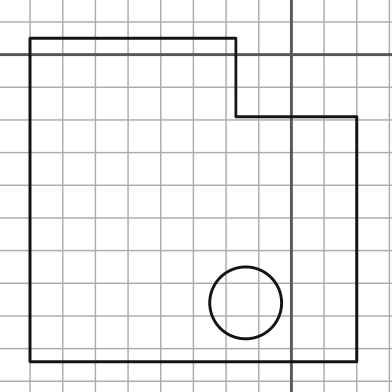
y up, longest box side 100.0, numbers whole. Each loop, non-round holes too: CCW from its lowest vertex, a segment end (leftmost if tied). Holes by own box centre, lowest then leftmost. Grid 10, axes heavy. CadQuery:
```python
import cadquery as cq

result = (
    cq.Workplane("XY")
    .moveTo(-80.0, -94.0)
    .lineTo(20.0, -94.0)
    .lineTo(20.0, -19.0)
    .lineTo(-17.0, -19.0)
    .lineTo(-17.0, 5.0)
    .lineTo(-80.0, 5.0)
    .close()
    .moveTo(-14.0, -76.0)
    .circle(11.0)
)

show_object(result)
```